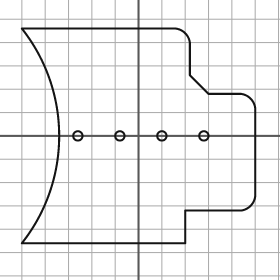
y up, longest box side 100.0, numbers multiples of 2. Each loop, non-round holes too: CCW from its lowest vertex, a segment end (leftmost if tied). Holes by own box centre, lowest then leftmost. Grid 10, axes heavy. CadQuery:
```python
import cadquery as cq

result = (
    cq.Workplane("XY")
    .moveTo(-50.0, -46.0)
    .lineTo(20.0, -46.0)
    .lineTo(20.0, -32.0)
    .lineTo(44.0, -32.0)
    .threePointArc((48.0, -30.0), (50.0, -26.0))
    .lineTo(50.0, 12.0)
    .threePointArc((48.0, 16.0), (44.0, 18.0))
    .lineTo(30.0, 18.0)
    .lineTo(22.0, 26.0)
    .lineTo(22.0, 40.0)
    .threePointArc((20.0, 44.0), (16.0, 46.0))
    .lineTo(-50.0, 46.0)
    .threePointArc((-34.0, 0.0), (-50.0, -46.0))
    .close()
    .moveTo(-26.0, 0.0)
    .circle(2.0)
    .moveTo(-8.0, 0.0)
    .circle(2.0)
    .moveTo(10.0, 0.0)
    .circle(2.0)
    .moveTo(28.0, 0.0)
    .circle(2.0)
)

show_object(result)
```